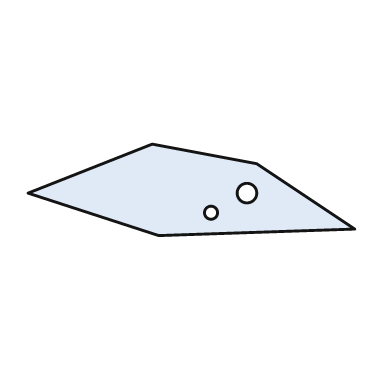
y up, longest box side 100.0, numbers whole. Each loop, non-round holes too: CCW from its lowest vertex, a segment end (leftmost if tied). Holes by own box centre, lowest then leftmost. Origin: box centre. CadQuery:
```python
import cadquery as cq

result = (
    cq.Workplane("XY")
    .moveTo(-10.0, -14.0)
    .lineTo(50.0, -12.0)
    .lineTo(20.0, 8.0)
    .lineTo(-12.0, 14.0)
    .lineTo(-50.0, -1.0)
    .close()
    .moveTo(6.0, -7.0)
    .circle(2.0)
    .moveTo(17.0, -1.0)
    .circle(3.0)
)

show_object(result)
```